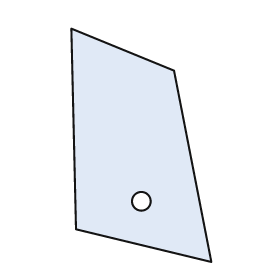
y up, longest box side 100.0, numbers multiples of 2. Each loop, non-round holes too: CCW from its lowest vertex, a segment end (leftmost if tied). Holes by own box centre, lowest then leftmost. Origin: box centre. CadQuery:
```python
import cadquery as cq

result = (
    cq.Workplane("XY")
    .moveTo(30.0, -50.0)
    .lineTo(14.0, 32.0)
    .lineTo(-30.0, 50.0)
    .lineTo(-28.0, -36.0)
    .close()
    .moveTo(0.0, -24.0)
    .circle(4.0)
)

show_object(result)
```